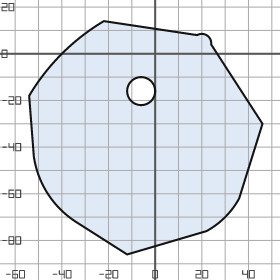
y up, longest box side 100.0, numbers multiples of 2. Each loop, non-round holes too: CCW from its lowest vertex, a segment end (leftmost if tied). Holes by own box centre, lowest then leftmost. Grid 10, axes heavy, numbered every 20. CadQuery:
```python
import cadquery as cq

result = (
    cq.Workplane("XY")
    .moveTo(-12.0, -86.0)
    .lineTo(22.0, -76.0)
    .threePointArc((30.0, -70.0), (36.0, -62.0))
    .lineTo(46.0, -30.0)
    .lineTo(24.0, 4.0)
    .threePointArc((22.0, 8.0), (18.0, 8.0))
    .lineTo(-22.0, 14.0)
    .threePointArc((-40.0, 0.0), (-54.0, -18.0))
    .lineTo(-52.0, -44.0)
    .threePointArc((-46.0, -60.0), (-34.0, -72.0))
    .close()
    .moveTo(-6.0, -16.0)
    .circle(6.0)
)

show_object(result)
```